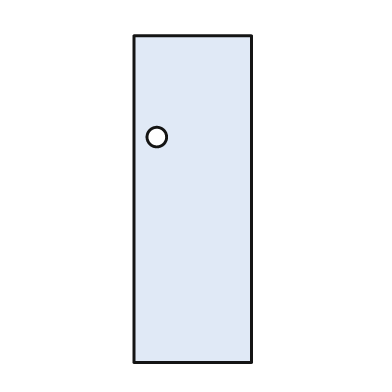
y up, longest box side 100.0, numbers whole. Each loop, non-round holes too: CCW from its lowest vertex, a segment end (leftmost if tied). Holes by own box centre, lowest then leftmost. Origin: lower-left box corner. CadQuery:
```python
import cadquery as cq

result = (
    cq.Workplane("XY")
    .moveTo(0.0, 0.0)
    .lineTo(36.0, 0.0)
    .lineTo(36.0, 100.0)
    .lineTo(0.0, 100.0)
    .close()
    .moveTo(7.0, 69.0)
    .circle(3.0)
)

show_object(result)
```